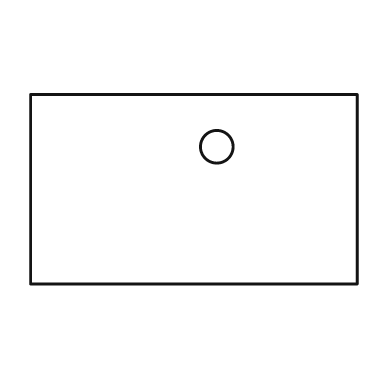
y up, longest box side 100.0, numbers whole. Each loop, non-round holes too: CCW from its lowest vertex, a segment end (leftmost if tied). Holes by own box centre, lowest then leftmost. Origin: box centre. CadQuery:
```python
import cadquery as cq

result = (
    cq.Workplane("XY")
    .moveTo(-50.0, -29.0)
    .lineTo(50.0, -29.0)
    .lineTo(50.0, 29.0)
    .lineTo(-50.0, 29.0)
    .close()
    .moveTo(7.0, 13.0)
    .circle(5.0)
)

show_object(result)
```